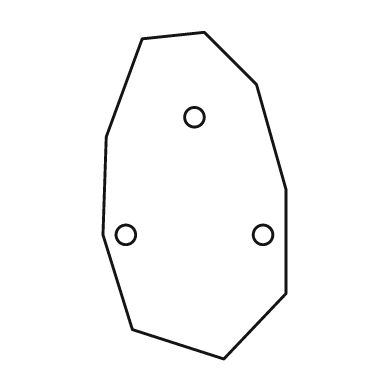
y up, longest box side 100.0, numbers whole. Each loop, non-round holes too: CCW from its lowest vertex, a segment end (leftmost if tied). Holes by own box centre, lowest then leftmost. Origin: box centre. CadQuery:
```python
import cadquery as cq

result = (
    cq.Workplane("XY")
    .moveTo(9.0, -50.0)
    .lineTo(28.0, -30.0)
    .lineTo(28.0, 2.0)
    .lineTo(19.0, 34.0)
    .lineTo(3.0, 50.0)
    .lineTo(-16.0, 48.0)
    .lineTo(-27.0, 18.0)
    .lineTo(-28.0, -12.0)
    .lineTo(-19.0, -41.0)
    .close()
    .moveTo(-21.0, -12.0)
    .circle(3.0)
    .moveTo(21.0, -12.0)
    .circle(3.0)
    .moveTo(0.0, 24.0)
    .circle(3.0)
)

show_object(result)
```